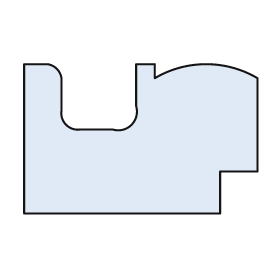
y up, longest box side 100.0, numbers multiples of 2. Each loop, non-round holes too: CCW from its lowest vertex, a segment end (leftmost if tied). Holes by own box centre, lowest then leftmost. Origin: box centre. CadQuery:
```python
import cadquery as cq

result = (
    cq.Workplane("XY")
    .moveTo(-50.0, -32.0)
    .lineTo(34.0, -32.0)
    .lineTo(34.0, -14.0)
    .lineTo(50.0, -14.0)
    .lineTo(50.0, 26.0)
    .threePointArc((28.0, 32.0), (6.0, 26.0))
    .lineTo(6.0, 32.0)
    .lineTo(-2.0, 32.0)
    .lineTo(-2.0, 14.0)
    .threePointArc((-4.0, 6.0), (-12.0, 4.0))
    .lineTo(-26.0, 4.0)
    .threePointArc((-32.0, 6.0), (-34.0, 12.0))
    .lineTo(-34.0, 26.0)
    .threePointArc((-36.0, 30.0), (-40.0, 32.0))
    .lineTo(-50.0, 32.0)
    .close()
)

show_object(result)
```